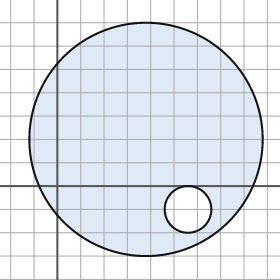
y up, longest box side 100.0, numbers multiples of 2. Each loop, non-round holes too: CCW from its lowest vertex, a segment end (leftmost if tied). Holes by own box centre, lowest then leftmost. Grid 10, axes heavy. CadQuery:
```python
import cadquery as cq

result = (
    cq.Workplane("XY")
    .moveTo(38.0, 20.0)
    .circle(50.0)
    .moveTo(56.0, -10.0)
    .circle(10.0)
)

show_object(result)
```